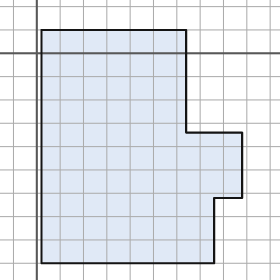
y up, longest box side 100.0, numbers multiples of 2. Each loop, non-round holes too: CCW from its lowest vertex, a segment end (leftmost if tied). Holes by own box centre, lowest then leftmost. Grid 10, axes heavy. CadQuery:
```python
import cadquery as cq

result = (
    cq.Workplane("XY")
    .moveTo(2.0, -90.0)
    .lineTo(76.0, -90.0)
    .lineTo(76.0, -62.0)
    .lineTo(88.0, -62.0)
    .lineTo(88.0, -34.0)
    .lineTo(64.0, -34.0)
    .lineTo(64.0, 10.0)
    .lineTo(2.0, 10.0)
    .close()
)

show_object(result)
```